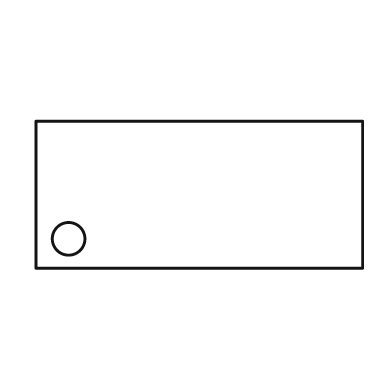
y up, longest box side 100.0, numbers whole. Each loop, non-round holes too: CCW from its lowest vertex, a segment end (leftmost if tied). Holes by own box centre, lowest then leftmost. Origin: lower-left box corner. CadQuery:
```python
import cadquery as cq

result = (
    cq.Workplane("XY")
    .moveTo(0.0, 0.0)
    .lineTo(100.0, 0.0)
    .lineTo(100.0, 45.0)
    .lineTo(0.0, 45.0)
    .close()
    .moveTo(10.0, 9.0)
    .circle(5.0)
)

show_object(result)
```